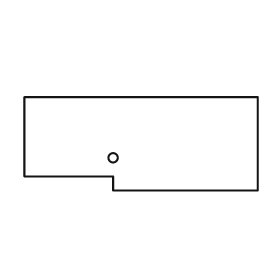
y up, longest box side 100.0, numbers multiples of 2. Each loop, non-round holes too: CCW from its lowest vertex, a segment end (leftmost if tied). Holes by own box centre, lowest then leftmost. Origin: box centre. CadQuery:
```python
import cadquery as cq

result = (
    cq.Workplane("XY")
    .moveTo(-12.0, -20.0)
    .lineTo(50.0, -20.0)
    .lineTo(50.0, 20.0)
    .lineTo(-50.0, 20.0)
    .lineTo(-50.0, -14.0)
    .lineTo(-12.0, -14.0)
    .close()
    .moveTo(-12.0, -6.0)
    .circle(2.0)
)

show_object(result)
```